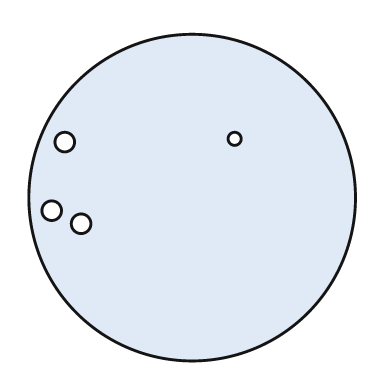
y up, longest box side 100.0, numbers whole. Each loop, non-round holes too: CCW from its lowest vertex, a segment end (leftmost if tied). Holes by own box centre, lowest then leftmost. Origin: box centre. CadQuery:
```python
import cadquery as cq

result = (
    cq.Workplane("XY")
    .moveTo(0.0, 0.0)
    .circle(50.0)
    .moveTo(-34.0, -8.0)
    .circle(3.0)
    .moveTo(-43.0, -4.0)
    .circle(3.0)
    .moveTo(-39.0, 17.0)
    .circle(3.0)
    .moveTo(13.0, 18.0)
    .circle(2.0)
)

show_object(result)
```